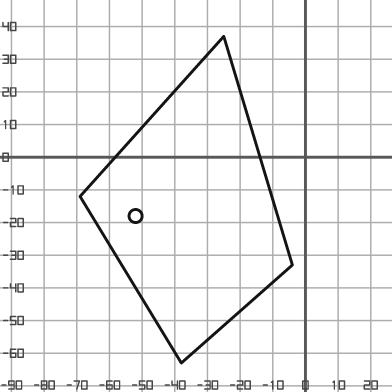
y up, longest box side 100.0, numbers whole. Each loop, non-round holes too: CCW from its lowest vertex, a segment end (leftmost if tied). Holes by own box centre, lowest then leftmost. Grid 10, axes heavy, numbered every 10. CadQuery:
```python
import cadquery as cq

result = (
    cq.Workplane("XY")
    .moveTo(-38.0, -63.0)
    .lineTo(-4.0, -33.0)
    .lineTo(-25.0, 37.0)
    .lineTo(-69.0, -12.0)
    .close()
    .moveTo(-52.0, -18.0)
    .circle(2.0)
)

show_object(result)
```